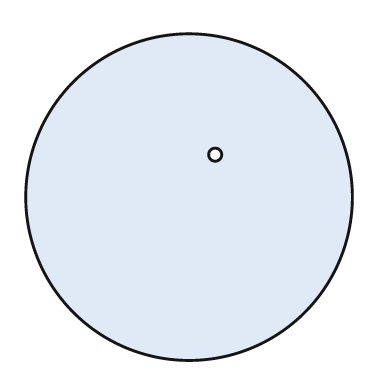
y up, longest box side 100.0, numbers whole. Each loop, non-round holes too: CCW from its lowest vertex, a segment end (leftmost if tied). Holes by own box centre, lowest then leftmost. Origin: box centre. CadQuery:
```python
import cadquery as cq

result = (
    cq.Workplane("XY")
    .moveTo(0.0, 0.0)
    .circle(50.0)
    .moveTo(8.0, 13.0)
    .circle(2.0)
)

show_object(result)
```